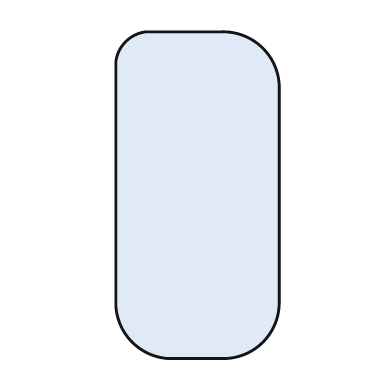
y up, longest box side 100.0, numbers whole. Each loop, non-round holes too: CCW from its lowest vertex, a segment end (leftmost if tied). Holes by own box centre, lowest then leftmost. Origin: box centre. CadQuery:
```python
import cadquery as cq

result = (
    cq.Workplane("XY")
    .moveTo(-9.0, -50.0)
    .lineTo(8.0, -50.0)
    .threePointArc((20.0, -45.0), (25.0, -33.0))
    .lineTo(25.0, 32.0)
    .threePointArc((20.0, 45.0), (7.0, 50.0))
    .lineTo(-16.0, 50.0)
    .threePointArc((-22.0, 47.0), (-25.0, 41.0))
    .lineTo(-25.0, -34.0)
    .threePointArc((-20.0, -45.0), (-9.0, -50.0))
    .close()
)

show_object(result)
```